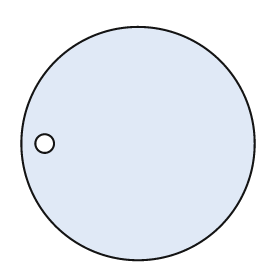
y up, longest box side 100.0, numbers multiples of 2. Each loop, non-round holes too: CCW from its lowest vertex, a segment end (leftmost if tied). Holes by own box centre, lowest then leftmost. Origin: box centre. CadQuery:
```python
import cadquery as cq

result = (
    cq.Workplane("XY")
    .moveTo(0.0, 0.0)
    .circle(50.0)
    .moveTo(-40.0, 0.0)
    .circle(4.0)
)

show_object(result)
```